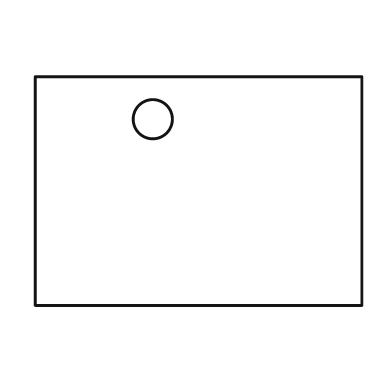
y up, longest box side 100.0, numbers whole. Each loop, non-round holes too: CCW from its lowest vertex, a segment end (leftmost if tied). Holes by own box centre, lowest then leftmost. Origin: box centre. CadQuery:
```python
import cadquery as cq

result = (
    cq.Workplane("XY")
    .moveTo(-50.0, -35.0)
    .lineTo(50.0, -35.0)
    .lineTo(50.0, 35.0)
    .lineTo(-50.0, 35.0)
    .close()
    .moveTo(-14.0, 22.0)
    .circle(6.0)
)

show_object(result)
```